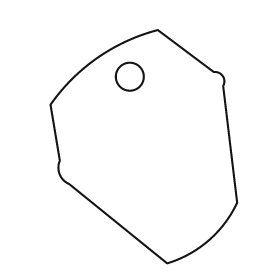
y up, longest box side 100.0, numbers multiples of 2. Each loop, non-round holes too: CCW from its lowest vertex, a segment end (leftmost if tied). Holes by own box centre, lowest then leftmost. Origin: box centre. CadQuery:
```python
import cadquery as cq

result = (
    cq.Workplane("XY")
    .moveTo(10.0, -50.0)
    .threePointArc((28.0, -40.0), (40.0, -24.0))
    .lineTo(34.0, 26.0)
    .threePointArc((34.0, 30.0), (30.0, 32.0))
    .lineTo(6.0, 50.0)
    .threePointArc((-20.0, 38.0), (-40.0, 18.0))
    .lineTo(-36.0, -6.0)
    .threePointArc((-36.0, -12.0), (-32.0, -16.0))
    .close()
    .moveTo(-6.0, 30.0)
    .circle(6.0)
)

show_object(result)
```